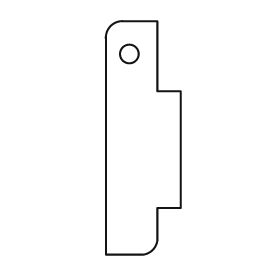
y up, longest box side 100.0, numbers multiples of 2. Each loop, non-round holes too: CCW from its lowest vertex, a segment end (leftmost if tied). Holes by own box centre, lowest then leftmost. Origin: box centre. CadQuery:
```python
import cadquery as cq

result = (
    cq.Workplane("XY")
    .moveTo(-16.0, -50.0)
    .lineTo(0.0, -50.0)
    .threePointArc((4.0, -48.0), (6.0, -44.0))
    .lineTo(6.0, -30.0)
    .lineTo(16.0, -30.0)
    .lineTo(16.0, 20.0)
    .lineTo(6.0, 20.0)
    .lineTo(6.0, 50.0)
    .lineTo(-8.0, 50.0)
    .threePointArc((-14.0, 48.0), (-16.0, 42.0))
    .close()
    .moveTo(-6.0, 36.0)
    .circle(4.0)
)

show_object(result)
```